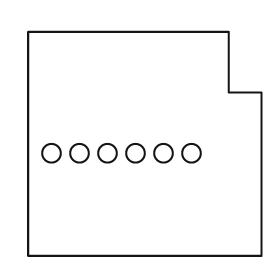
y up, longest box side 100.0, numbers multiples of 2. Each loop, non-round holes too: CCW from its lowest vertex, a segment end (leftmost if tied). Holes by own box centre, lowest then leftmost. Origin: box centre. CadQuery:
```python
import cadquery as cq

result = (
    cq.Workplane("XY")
    .moveTo(-50.0, -48.0)
    .lineTo(50.0, -48.0)
    .lineTo(50.0, 22.0)
    .lineTo(36.0, 22.0)
    .lineTo(36.0, 48.0)
    .lineTo(-50.0, 48.0)
    .close()
    .moveTo(-40.0, -4.0)
    .circle(4.0)
    .moveTo(-28.0, -4.0)
    .circle(4.0)
    .moveTo(-16.0, -4.0)
    .circle(4.0)
    .moveTo(-4.0, -4.0)
    .circle(4.0)
    .moveTo(8.0, -4.0)
    .circle(4.0)
    .moveTo(20.0, -4.0)
    .circle(4.0)
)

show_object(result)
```